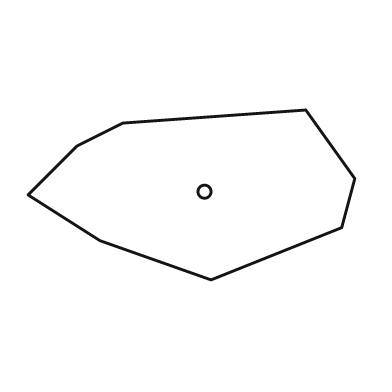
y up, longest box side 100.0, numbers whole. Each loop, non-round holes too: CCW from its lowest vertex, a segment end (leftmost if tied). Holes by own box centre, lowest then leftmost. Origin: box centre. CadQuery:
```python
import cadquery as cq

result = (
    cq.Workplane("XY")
    .moveTo(6.0, -26.0)
    .lineTo(46.0, -10.0)
    .lineTo(50.0, 5.0)
    .lineTo(35.0, 26.0)
    .lineTo(-21.0, 22.0)
    .lineTo(-35.0, 15.0)
    .lineTo(-50.0, 0.0)
    .lineTo(-28.0, -14.0)
    .close()
    .moveTo(4.0, 1.0)
    .circle(2.0)
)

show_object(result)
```